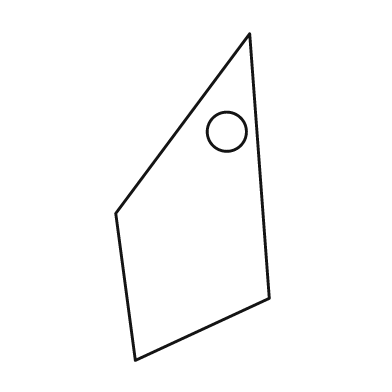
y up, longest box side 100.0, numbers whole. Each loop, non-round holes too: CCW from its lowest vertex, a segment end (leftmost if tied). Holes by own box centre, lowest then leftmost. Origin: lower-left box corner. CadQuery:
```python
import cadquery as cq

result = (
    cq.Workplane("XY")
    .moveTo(6.0, 0.0)
    .lineTo(47.0, 19.0)
    .lineTo(41.0, 100.0)
    .lineTo(0.0, 45.0)
    .close()
    .moveTo(34.0, 70.0)
    .circle(6.0)
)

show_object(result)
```